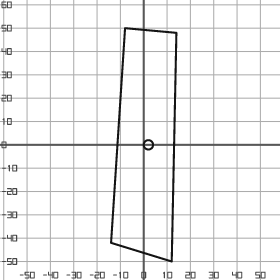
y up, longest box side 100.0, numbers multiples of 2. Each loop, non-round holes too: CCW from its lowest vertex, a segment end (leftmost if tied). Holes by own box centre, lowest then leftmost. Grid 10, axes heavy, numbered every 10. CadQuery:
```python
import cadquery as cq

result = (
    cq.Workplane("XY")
    .moveTo(12.0, -50.0)
    .lineTo(14.0, 48.0)
    .lineTo(-8.0, 50.0)
    .lineTo(-14.0, -42.0)
    .close()
    .moveTo(2.0, 0.0)
    .circle(2.0)
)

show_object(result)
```